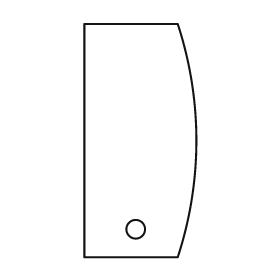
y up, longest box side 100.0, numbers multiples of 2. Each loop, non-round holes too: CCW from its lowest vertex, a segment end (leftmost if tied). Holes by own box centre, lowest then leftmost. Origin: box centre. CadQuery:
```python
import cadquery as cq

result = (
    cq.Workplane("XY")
    .moveTo(-24.0, -50.0)
    .lineTo(16.0, -50.0)
    .threePointArc((24.0, 0.0), (16.0, 50.0))
    .lineTo(-24.0, 50.0)
    .close()
    .moveTo(-2.0, -38.0)
    .circle(4.0)
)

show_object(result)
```